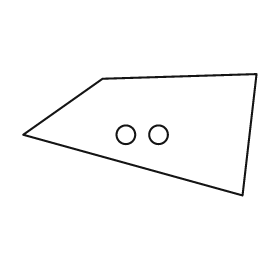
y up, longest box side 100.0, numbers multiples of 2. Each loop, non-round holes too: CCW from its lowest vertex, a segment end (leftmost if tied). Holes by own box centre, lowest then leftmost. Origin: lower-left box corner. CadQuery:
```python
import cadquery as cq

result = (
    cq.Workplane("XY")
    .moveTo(94.0, 0.0)
    .lineTo(100.0, 52.0)
    .lineTo(34.0, 50.0)
    .lineTo(0.0, 26.0)
    .close()
    .moveTo(44.0, 26.0)
    .circle(4.0)
    .moveTo(58.0, 26.0)
    .circle(4.0)
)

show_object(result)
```